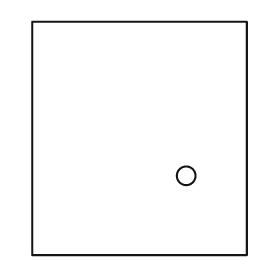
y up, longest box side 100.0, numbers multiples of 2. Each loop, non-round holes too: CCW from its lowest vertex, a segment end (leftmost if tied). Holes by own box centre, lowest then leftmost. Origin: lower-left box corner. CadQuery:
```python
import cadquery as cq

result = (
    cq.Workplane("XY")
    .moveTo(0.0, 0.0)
    .lineTo(92.0, 0.0)
    .lineTo(92.0, 100.0)
    .lineTo(0.0, 100.0)
    .close()
    .moveTo(66.0, 34.0)
    .circle(4.0)
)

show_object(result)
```